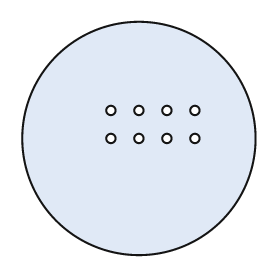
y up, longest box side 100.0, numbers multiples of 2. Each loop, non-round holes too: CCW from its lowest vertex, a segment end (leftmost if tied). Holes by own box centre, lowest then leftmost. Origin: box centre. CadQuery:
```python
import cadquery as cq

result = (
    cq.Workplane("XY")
    .moveTo(0.0, 0.0)
    .circle(50.0)
    .moveTo(-12.0, 0.0)
    .circle(2.0)
    .moveTo(0.0, 0.0)
    .circle(2.0)
    .moveTo(12.0, 0.0)
    .circle(2.0)
    .moveTo(24.0, 0.0)
    .circle(2.0)
    .moveTo(-12.0, 12.0)
    .circle(2.0)
    .moveTo(0.0, 12.0)
    .circle(2.0)
    .moveTo(12.0, 12.0)
    .circle(2.0)
    .moveTo(24.0, 12.0)
    .circle(2.0)
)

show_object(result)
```